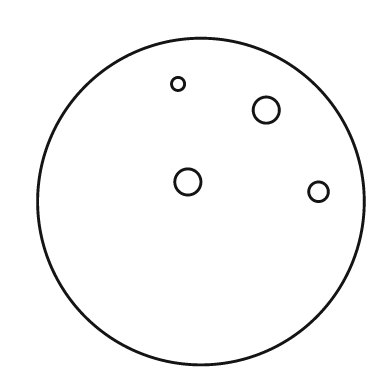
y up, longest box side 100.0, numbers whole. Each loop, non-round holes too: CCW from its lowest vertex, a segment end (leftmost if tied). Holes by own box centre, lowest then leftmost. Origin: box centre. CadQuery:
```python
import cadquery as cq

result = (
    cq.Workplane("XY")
    .moveTo(0.0, 0.0)
    .circle(50.0)
    .moveTo(36.0, 3.0)
    .circle(3.0)
    .moveTo(-4.0, 6.0)
    .circle(4.0)
    .moveTo(20.0, 28.0)
    .circle(4.0)
    .moveTo(-7.0, 36.0)
    .circle(2.0)
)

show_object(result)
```